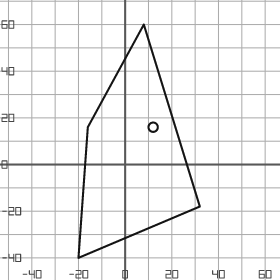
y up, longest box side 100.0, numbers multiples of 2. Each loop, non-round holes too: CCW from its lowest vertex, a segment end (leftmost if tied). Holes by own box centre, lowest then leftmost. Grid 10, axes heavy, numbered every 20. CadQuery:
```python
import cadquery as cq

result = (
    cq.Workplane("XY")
    .moveTo(-20.0, -40.0)
    .lineTo(32.0, -18.0)
    .lineTo(8.0, 60.0)
    .lineTo(-16.0, 16.0)
    .close()
    .moveTo(12.0, 16.0)
    .circle(2.0)
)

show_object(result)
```